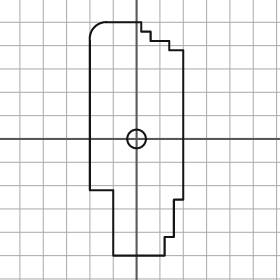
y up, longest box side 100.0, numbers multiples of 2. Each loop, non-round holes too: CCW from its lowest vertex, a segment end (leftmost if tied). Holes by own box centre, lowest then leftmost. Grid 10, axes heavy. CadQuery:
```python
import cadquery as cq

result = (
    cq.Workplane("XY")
    .moveTo(-10.0, -50.0)
    .lineTo(12.0, -50.0)
    .lineTo(12.0, -42.0)
    .lineTo(16.0, -42.0)
    .lineTo(16.0, -26.0)
    .lineTo(20.0, -26.0)
    .lineTo(20.0, 38.0)
    .lineTo(14.0, 38.0)
    .lineTo(14.0, 42.0)
    .lineTo(6.0, 42.0)
    .lineTo(6.0, 46.0)
    .lineTo(2.0, 46.0)
    .lineTo(2.0, 50.0)
    .lineTo(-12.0, 50.0)
    .threePointArc((-18.0, 48.0), (-20.0, 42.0))
    .lineTo(-20.0, -22.0)
    .lineTo(-10.0, -22.0)
    .close()
    .moveTo(0.0, 0.0)
    .circle(4.0)
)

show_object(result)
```